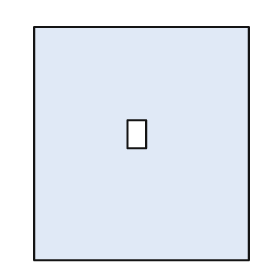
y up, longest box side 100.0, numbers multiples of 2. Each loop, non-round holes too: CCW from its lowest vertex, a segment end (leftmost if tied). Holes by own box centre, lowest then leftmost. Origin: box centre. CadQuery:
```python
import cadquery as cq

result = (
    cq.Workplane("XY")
    .moveTo(-46.0, -50.0)
    .lineTo(46.0, -50.0)
    .lineTo(46.0, 50.0)
    .lineTo(-46.0, 50.0)
    .close()
    .moveTo(-6.0, -2.0)
    .lineTo(2.0, -2.0)
    .lineTo(2.0, 10.0)
    .lineTo(-6.0, 10.0)
    .close()
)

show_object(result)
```